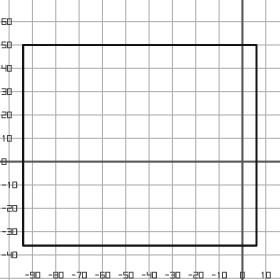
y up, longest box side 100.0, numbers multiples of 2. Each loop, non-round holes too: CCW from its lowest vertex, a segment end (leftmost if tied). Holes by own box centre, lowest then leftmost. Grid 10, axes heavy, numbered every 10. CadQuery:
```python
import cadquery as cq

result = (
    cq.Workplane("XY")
    .moveTo(-94.0, -36.0)
    .lineTo(6.0, -36.0)
    .lineTo(6.0, 50.0)
    .lineTo(-94.0, 50.0)
    .close()
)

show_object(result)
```